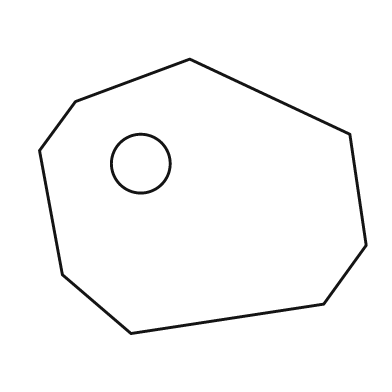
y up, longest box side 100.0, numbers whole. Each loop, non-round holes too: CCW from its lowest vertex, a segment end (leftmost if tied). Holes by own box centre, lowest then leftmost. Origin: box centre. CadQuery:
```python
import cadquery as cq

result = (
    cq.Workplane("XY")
    .moveTo(-22.0, -42.0)
    .lineTo(37.0, -33.0)
    .lineTo(50.0, -15.0)
    .lineTo(45.0, 19.0)
    .lineTo(-4.0, 42.0)
    .lineTo(-39.0, 29.0)
    .lineTo(-50.0, 14.0)
    .lineTo(-43.0, -24.0)
    .close()
    .moveTo(-19.0, 10.0)
    .circle(9.0)
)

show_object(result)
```